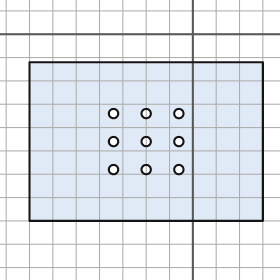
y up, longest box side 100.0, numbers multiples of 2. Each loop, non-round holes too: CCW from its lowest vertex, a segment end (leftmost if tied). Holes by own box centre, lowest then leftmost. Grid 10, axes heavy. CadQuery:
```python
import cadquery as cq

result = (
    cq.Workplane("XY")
    .moveTo(-70.0, -80.0)
    .lineTo(30.0, -80.0)
    .lineTo(30.0, -12.0)
    .lineTo(-70.0, -12.0)
    .close()
    .moveTo(-34.0, -58.0)
    .circle(2.0)
    .moveTo(-20.0, -58.0)
    .circle(2.0)
    .moveTo(-6.0, -58.0)
    .circle(2.0)
    .moveTo(-34.0, -46.0)
    .circle(2.0)
    .moveTo(-20.0, -46.0)
    .circle(2.0)
    .moveTo(-6.0, -46.0)
    .circle(2.0)
    .moveTo(-34.0, -34.0)
    .circle(2.0)
    .moveTo(-20.0, -34.0)
    .circle(2.0)
    .moveTo(-6.0, -34.0)
    .circle(2.0)
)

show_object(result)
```